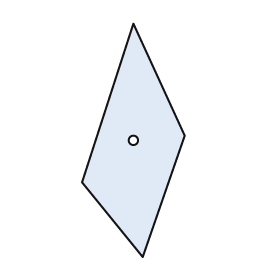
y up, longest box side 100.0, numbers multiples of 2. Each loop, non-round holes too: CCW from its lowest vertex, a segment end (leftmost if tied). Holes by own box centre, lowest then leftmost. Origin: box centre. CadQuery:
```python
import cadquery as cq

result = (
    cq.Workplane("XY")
    .moveTo(4.0, -50.0)
    .lineTo(22.0, 2.0)
    .lineTo(0.0, 50.0)
    .lineTo(-22.0, -18.0)
    .close()
    .moveTo(0.0, 0.0)
    .circle(2.0)
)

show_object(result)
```